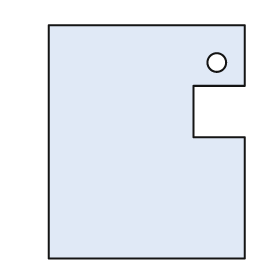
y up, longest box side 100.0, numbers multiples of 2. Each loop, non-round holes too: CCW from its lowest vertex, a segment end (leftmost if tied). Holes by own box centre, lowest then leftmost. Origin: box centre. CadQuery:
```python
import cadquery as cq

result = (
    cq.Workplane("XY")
    .moveTo(-42.0, -50.0)
    .lineTo(42.0, -50.0)
    .lineTo(42.0, 2.0)
    .lineTo(20.0, 2.0)
    .lineTo(20.0, 24.0)
    .lineTo(42.0, 24.0)
    .lineTo(42.0, 50.0)
    .lineTo(-42.0, 50.0)
    .close()
    .moveTo(30.0, 34.0)
    .circle(4.0)
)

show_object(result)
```